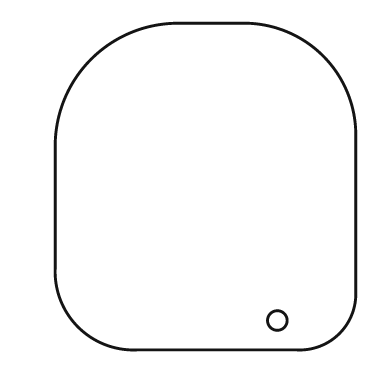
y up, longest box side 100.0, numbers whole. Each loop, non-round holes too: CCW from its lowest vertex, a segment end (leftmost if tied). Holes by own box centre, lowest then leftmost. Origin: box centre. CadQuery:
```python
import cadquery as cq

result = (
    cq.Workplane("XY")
    .moveTo(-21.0, -50.0)
    .lineTo(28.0, -50.0)
    .threePointArc((41.0, -45.0), (46.0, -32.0))
    .lineTo(46.0, 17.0)
    .threePointArc((36.0, 40.0), (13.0, 50.0))
    .lineTo(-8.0, 50.0)
    .threePointArc((-35.0, 39.0), (-46.0, 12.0))
    .lineTo(-46.0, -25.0)
    .threePointArc((-39.0, -43.0), (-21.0, -50.0))
    .close()
    .moveTo(22.0, -41.0)
    .circle(3.0)
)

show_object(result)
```